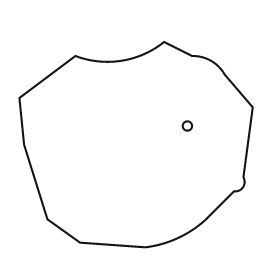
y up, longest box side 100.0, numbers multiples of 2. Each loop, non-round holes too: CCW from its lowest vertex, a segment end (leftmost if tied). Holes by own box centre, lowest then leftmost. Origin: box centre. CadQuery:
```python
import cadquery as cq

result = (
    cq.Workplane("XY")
    .moveTo(4.0, -44.0)
    .threePointArc((18.0, -40.0), (30.0, -32.0))
    .lineTo(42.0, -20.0)
    .threePointArc((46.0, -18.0), (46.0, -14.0))
    .lineTo(50.0, 16.0)
    .lineTo(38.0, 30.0)
    .threePointArc((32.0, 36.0), (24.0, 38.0))
    .lineTo(12.0, 44.0)
    .threePointArc((-6.0, 36.0), (-26.0, 38.0))
    .lineTo(-50.0, 20.0)
    .lineTo(-48.0, 0.0)
    .lineTo(-38.0, -32.0)
    .lineTo(-24.0, -42.0)
    .close()
    .moveTo(22.0, 8.0)
    .circle(2.0)
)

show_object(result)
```